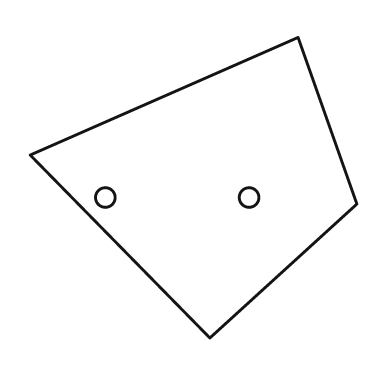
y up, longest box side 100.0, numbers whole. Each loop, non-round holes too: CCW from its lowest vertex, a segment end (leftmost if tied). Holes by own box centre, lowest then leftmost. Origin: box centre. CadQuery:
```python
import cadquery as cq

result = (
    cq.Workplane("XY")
    .moveTo(5.0, -46.0)
    .lineTo(50.0, -5.0)
    .lineTo(32.0, 46.0)
    .lineTo(-50.0, 10.0)
    .close()
    .moveTo(-27.0, -3.0)
    .circle(3.0)
    .moveTo(17.0, -3.0)
    .circle(3.0)
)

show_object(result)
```